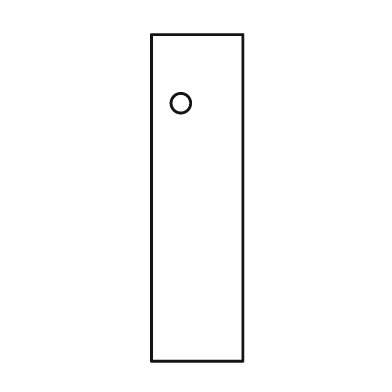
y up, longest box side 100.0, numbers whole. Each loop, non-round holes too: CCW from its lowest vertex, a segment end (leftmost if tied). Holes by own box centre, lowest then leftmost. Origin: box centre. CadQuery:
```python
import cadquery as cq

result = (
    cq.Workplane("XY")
    .moveTo(-14.0, -50.0)
    .lineTo(14.0, -50.0)
    .lineTo(14.0, 50.0)
    .lineTo(-14.0, 50.0)
    .close()
    .moveTo(-5.0, 29.0)
    .circle(3.0)
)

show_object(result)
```